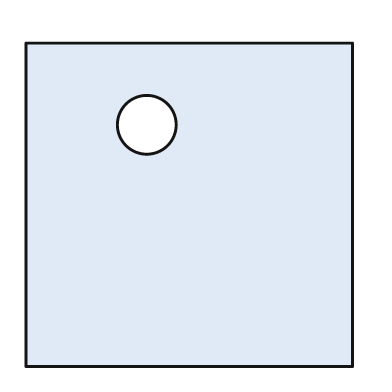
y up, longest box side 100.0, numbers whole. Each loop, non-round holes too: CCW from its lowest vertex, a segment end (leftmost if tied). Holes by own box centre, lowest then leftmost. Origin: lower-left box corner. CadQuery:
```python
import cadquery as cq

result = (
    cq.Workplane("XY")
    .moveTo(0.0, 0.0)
    .lineTo(100.0, 0.0)
    .lineTo(100.0, 99.0)
    .lineTo(0.0, 99.0)
    .close()
    .moveTo(37.0, 74.0)
    .circle(9.0)
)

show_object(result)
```